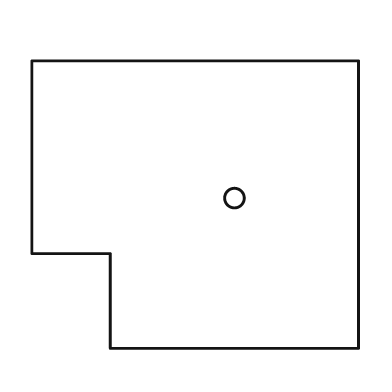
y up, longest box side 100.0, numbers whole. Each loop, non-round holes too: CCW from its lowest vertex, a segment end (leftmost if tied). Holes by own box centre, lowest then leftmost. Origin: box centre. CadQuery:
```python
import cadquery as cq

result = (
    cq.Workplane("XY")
    .moveTo(-26.0, -44.0)
    .lineTo(50.0, -44.0)
    .lineTo(50.0, 44.0)
    .lineTo(-50.0, 44.0)
    .lineTo(-50.0, -15.0)
    .lineTo(-26.0, -15.0)
    .close()
    .moveTo(12.0, 2.0)
    .circle(3.0)
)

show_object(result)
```